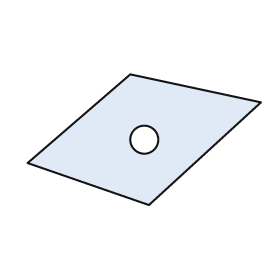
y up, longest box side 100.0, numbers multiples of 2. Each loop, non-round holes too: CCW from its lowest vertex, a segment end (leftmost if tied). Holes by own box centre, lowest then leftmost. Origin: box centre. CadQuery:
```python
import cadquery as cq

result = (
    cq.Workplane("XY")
    .moveTo(2.0, -28.0)
    .lineTo(50.0, 16.0)
    .lineTo(-6.0, 28.0)
    .lineTo(-50.0, -10.0)
    .close()
    .moveTo(0.0, 0.0)
    .circle(6.0)
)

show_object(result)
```